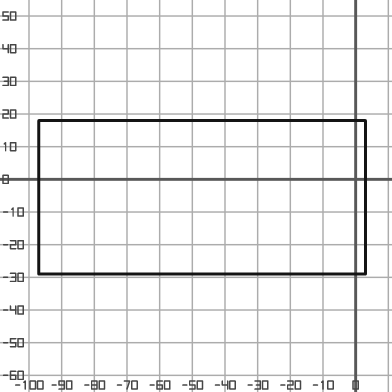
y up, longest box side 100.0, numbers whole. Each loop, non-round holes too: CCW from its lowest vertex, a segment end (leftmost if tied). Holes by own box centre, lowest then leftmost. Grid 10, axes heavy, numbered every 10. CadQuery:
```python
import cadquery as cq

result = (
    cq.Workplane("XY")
    .moveTo(-97.0, -29.0)
    .lineTo(3.0, -29.0)
    .lineTo(3.0, 18.0)
    .lineTo(-97.0, 18.0)
    .close()
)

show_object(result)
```